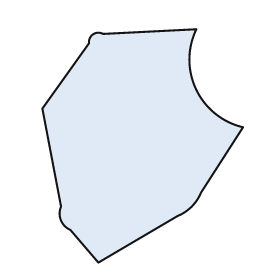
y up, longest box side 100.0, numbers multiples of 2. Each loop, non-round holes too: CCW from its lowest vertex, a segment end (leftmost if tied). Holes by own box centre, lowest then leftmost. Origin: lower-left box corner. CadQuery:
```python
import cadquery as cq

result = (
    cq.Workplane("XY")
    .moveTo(24.0, 0.0)
    .lineTo(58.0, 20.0)
    .threePointArc((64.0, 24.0), (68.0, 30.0))
    .lineTo(86.0, 58.0)
    .threePointArc((66.0, 74.0), (66.0, 100.0))
    .lineTo(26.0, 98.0)
    .threePointArc((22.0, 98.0), (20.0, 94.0))
    .lineTo(0.0, 66.0)
    .lineTo(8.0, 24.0)
    .threePointArc((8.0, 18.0), (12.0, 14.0))
    .close()
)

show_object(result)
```